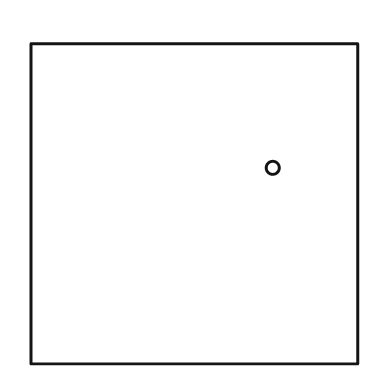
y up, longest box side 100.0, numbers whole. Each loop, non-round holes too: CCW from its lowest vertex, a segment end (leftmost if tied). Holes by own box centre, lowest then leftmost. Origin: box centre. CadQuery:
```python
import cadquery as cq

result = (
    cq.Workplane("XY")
    .moveTo(-50.0, -49.0)
    .lineTo(50.0, -49.0)
    .lineTo(50.0, 49.0)
    .lineTo(-50.0, 49.0)
    .close()
    .moveTo(24.0, 11.0)
    .circle(2.0)
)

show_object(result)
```